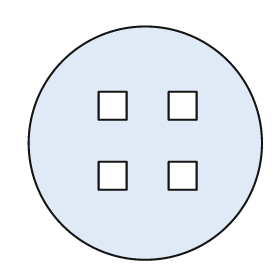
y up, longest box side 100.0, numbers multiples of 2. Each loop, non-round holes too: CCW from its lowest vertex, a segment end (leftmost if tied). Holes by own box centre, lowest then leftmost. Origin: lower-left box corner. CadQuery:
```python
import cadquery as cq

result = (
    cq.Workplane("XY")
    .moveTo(50.0, 50.0)
    .circle(50.0)
    .moveTo(30.0, 30.0)
    .lineTo(42.0, 30.0)
    .lineTo(42.0, 42.0)
    .lineTo(30.0, 42.0)
    .close()
    .moveTo(60.0, 30.0)
    .lineTo(72.0, 30.0)
    .lineTo(72.0, 42.0)
    .lineTo(60.0, 42.0)
    .close()
    .moveTo(30.0, 60.0)
    .lineTo(42.0, 60.0)
    .lineTo(42.0, 72.0)
    .lineTo(30.0, 72.0)
    .close()
    .moveTo(60.0, 60.0)
    .lineTo(72.0, 60.0)
    .lineTo(72.0, 72.0)
    .lineTo(60.0, 72.0)
    .close()
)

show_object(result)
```